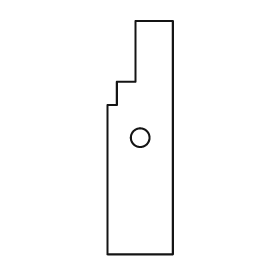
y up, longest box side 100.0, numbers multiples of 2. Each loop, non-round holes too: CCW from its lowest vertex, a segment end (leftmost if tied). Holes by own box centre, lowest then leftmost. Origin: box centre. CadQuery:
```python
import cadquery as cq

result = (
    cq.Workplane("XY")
    .moveTo(-14.0, -50.0)
    .lineTo(14.0, -50.0)
    .lineTo(14.0, 50.0)
    .lineTo(-2.0, 50.0)
    .lineTo(-2.0, 24.0)
    .lineTo(-10.0, 24.0)
    .lineTo(-10.0, 14.0)
    .lineTo(-14.0, 14.0)
    .close()
    .moveTo(0.0, 0.0)
    .circle(4.0)
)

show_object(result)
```